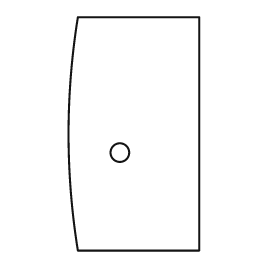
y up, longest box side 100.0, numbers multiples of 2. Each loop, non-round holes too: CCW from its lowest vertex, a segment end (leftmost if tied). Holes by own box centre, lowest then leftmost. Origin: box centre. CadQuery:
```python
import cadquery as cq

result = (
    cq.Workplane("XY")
    .moveTo(-24.0, -50.0)
    .lineTo(28.0, -50.0)
    .lineTo(28.0, 50.0)
    .lineTo(-24.0, 50.0)
    .threePointArc((-28.0, 0.0), (-24.0, -50.0))
    .close()
    .moveTo(-6.0, -8.0)
    .circle(4.0)
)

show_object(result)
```